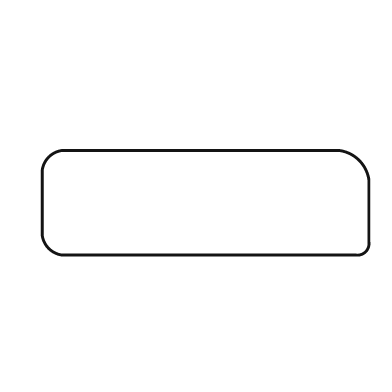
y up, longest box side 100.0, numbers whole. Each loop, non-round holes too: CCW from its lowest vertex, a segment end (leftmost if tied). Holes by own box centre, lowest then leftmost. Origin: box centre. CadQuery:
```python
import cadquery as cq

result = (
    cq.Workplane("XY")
    .moveTo(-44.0, -16.0)
    .lineTo(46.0, -16.0)
    .threePointArc((49.0, -15.0), (50.0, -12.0))
    .lineTo(50.0, 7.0)
    .threePointArc((47.0, 13.0), (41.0, 16.0))
    .lineTo(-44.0, 16.0)
    .threePointArc((-48.0, 14.0), (-50.0, 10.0))
    .lineTo(-50.0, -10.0)
    .threePointArc((-48.0, -14.0), (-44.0, -16.0))
    .close()
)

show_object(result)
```